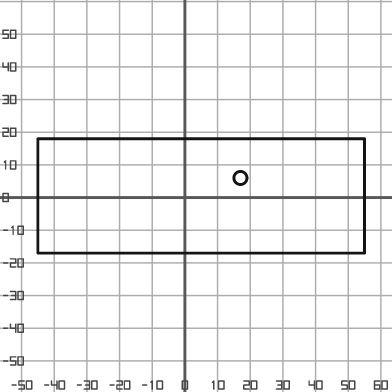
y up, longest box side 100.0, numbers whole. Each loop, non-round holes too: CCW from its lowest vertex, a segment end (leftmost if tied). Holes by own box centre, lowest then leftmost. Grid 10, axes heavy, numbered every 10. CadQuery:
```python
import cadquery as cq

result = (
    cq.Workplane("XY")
    .moveTo(-45.0, -17.0)
    .lineTo(55.0, -17.0)
    .lineTo(55.0, 18.0)
    .lineTo(-45.0, 18.0)
    .close()
    .moveTo(17.0, 6.0)
    .circle(2.0)
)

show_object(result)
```